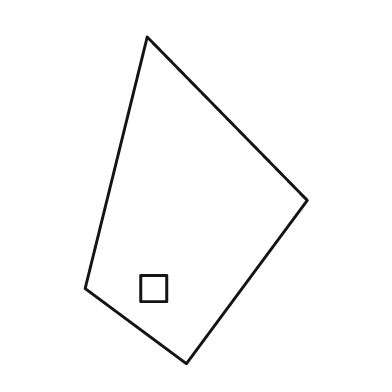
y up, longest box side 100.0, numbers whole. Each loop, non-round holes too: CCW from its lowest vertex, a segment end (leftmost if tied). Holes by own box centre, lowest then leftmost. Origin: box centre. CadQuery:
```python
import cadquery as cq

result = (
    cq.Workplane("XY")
    .moveTo(-3.0, -50.0)
    .lineTo(34.0, 0.0)
    .lineTo(-15.0, 50.0)
    .lineTo(-34.0, -27.0)
    .close()
    .moveTo(-17.0, -31.0)
    .lineTo(-9.0, -31.0)
    .lineTo(-9.0, -23.0)
    .lineTo(-17.0, -23.0)
    .close()
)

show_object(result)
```